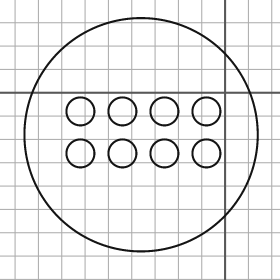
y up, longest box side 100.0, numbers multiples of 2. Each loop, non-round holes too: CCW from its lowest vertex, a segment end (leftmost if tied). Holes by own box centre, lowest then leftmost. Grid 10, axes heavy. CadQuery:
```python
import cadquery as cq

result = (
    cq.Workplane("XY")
    .moveTo(-36.0, -18.0)
    .circle(50.0)
    .moveTo(-62.0, -26.0)
    .circle(6.0)
    .moveTo(-44.0, -26.0)
    .circle(6.0)
    .moveTo(-26.0, -26.0)
    .circle(6.0)
    .moveTo(-8.0, -26.0)
    .circle(6.0)
    .moveTo(-62.0, -8.0)
    .circle(6.0)
    .moveTo(-44.0, -8.0)
    .circle(6.0)
    .moveTo(-26.0, -8.0)
    .circle(6.0)
    .moveTo(-8.0, -8.0)
    .circle(6.0)
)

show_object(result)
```